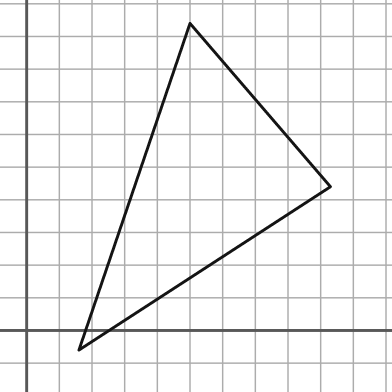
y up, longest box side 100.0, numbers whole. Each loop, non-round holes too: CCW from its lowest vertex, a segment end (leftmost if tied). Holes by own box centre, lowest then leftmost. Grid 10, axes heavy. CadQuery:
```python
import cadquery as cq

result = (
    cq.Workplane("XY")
    .moveTo(16.0, -6.0)
    .lineTo(93.0, 44.0)
    .lineTo(50.0, 94.0)
    .close()
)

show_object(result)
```